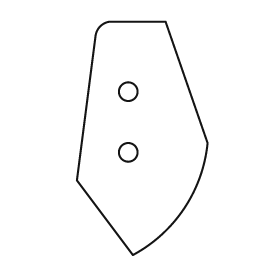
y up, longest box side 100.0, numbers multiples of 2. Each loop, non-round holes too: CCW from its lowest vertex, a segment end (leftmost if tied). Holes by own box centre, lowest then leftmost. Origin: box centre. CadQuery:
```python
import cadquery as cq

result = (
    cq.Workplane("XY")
    .moveTo(-4.0, -50.0)
    .threePointArc((18.0, -30.0), (28.0, -2.0))
    .lineTo(10.0, 50.0)
    .lineTo(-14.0, 50.0)
    .threePointArc((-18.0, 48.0), (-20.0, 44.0))
    .lineTo(-28.0, -18.0)
    .close()
    .moveTo(-6.0, -6.0)
    .circle(4.0)
    .moveTo(-6.0, 20.0)
    .circle(4.0)
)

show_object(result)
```